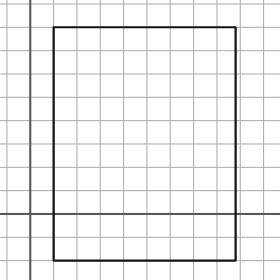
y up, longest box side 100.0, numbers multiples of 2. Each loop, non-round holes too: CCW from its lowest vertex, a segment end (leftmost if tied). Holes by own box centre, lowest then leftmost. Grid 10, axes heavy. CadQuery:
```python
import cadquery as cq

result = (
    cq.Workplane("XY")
    .moveTo(10.0, -20.0)
    .lineTo(88.0, -20.0)
    .lineTo(88.0, 80.0)
    .lineTo(10.0, 80.0)
    .close()
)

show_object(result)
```